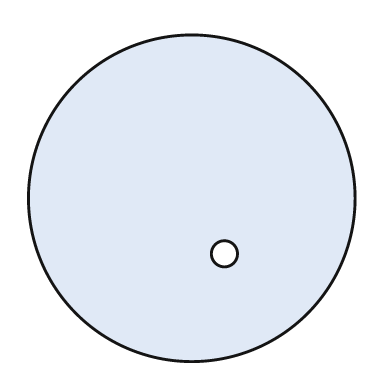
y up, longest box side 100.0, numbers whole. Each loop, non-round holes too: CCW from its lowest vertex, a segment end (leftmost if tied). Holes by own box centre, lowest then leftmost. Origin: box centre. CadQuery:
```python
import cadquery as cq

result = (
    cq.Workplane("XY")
    .moveTo(0.0, 0.0)
    .circle(50.0)
    .moveTo(10.0, -17.0)
    .circle(4.0)
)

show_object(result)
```